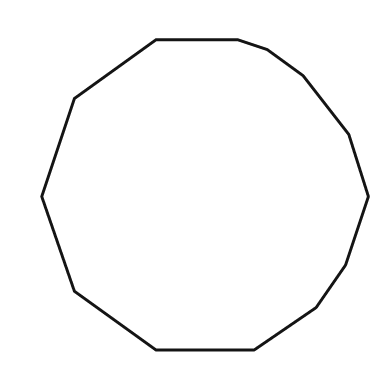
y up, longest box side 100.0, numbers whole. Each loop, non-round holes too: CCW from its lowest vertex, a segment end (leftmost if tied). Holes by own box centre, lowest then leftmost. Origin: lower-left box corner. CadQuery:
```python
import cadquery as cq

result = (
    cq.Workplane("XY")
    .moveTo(35.0, 0.0)
    .lineTo(65.0, 0.0)
    .lineTo(84.0, 13.0)
    .lineTo(93.0, 26.0)
    .lineTo(100.0, 47.0)
    .lineTo(94.0, 66.0)
    .lineTo(80.0, 84.0)
    .lineTo(69.0, 92.0)
    .lineTo(60.0, 95.0)
    .lineTo(35.0, 95.0)
    .lineTo(10.0, 77.0)
    .lineTo(0.0, 47.0)
    .lineTo(10.0, 18.0)
    .close()
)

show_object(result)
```